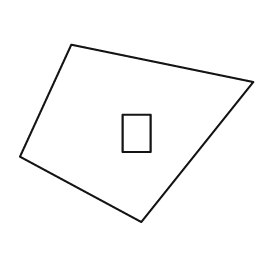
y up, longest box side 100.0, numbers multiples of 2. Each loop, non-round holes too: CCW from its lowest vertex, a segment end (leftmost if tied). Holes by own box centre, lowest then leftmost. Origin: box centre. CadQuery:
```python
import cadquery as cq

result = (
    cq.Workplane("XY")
    .moveTo(2.0, -38.0)
    .lineTo(50.0, 22.0)
    .lineTo(-28.0, 38.0)
    .lineTo(-50.0, -10.0)
    .close()
    .moveTo(-6.0, -8.0)
    .lineTo(6.0, -8.0)
    .lineTo(6.0, 8.0)
    .lineTo(-6.0, 8.0)
    .close()
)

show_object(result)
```